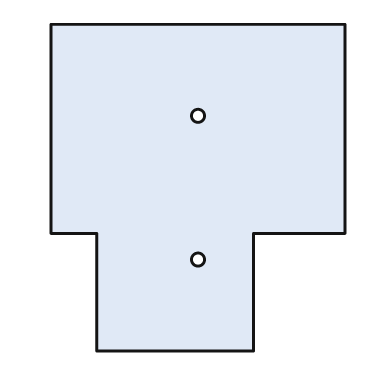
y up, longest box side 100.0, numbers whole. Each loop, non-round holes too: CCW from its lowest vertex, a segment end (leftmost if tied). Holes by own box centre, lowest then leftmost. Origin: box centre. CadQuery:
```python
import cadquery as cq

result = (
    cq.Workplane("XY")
    .moveTo(-31.0, -50.0)
    .lineTo(17.0, -50.0)
    .lineTo(17.0, -14.0)
    .lineTo(45.0, -14.0)
    .lineTo(45.0, 50.0)
    .lineTo(-45.0, 50.0)
    .lineTo(-45.0, -14.0)
    .lineTo(-31.0, -14.0)
    .close()
    .moveTo(0.0, -22.0)
    .circle(2.0)
    .moveTo(0.0, 22.0)
    .circle(2.0)
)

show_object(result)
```